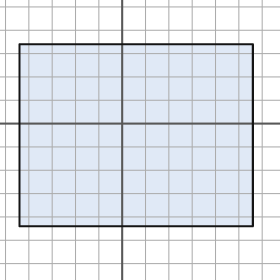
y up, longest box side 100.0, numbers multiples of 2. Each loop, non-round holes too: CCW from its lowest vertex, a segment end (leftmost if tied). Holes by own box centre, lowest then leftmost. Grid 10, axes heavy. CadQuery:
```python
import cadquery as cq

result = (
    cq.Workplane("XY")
    .moveTo(-44.0, -44.0)
    .lineTo(56.0, -44.0)
    .lineTo(56.0, 34.0)
    .lineTo(-44.0, 34.0)
    .close()
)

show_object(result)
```